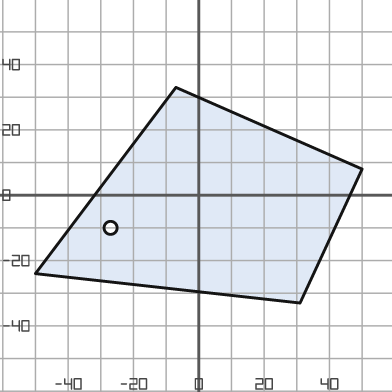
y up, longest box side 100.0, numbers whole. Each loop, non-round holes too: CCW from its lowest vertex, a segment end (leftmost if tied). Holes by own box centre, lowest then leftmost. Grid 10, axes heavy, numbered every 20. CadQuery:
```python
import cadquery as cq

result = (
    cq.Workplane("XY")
    .moveTo(31.0, -33.0)
    .lineTo(50.0, 8.0)
    .lineTo(-7.0, 33.0)
    .lineTo(-50.0, -24.0)
    .close()
    .moveTo(-27.0, -10.0)
    .circle(2.0)
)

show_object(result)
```